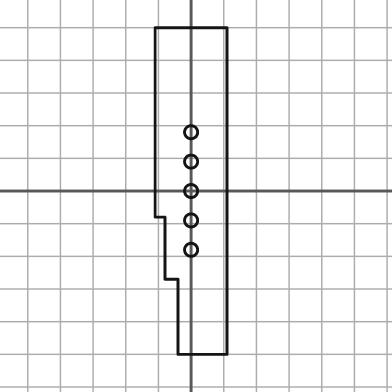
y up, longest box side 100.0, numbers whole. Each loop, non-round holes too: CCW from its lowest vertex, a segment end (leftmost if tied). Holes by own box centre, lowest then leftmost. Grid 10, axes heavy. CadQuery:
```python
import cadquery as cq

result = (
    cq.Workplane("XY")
    .moveTo(-4.0, -50.0)
    .lineTo(11.0, -50.0)
    .lineTo(11.0, 50.0)
    .lineTo(-11.0, 50.0)
    .lineTo(-11.0, -8.0)
    .lineTo(-8.0, -8.0)
    .lineTo(-8.0, -27.0)
    .lineTo(-4.0, -27.0)
    .close()
    .moveTo(0.0, -18.0)
    .circle(2.0)
    .moveTo(0.0, -9.0)
    .circle(2.0)
    .moveTo(0.0, 0.0)
    .circle(2.0)
    .moveTo(0.0, 9.0)
    .circle(2.0)
    .moveTo(0.0, 18.0)
    .circle(2.0)
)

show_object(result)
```